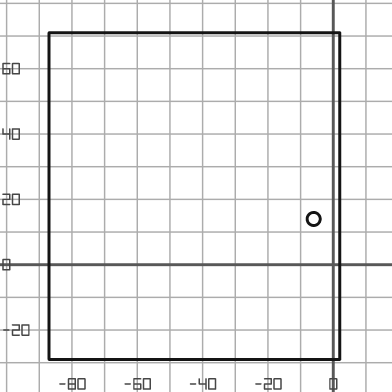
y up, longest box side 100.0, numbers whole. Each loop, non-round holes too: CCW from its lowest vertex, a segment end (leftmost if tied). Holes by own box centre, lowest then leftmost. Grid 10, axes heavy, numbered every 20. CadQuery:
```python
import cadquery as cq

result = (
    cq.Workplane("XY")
    .moveTo(-87.0, -29.0)
    .lineTo(2.0, -29.0)
    .lineTo(2.0, 71.0)
    .lineTo(-87.0, 71.0)
    .close()
    .moveTo(-6.0, 14.0)
    .circle(2.0)
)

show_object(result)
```